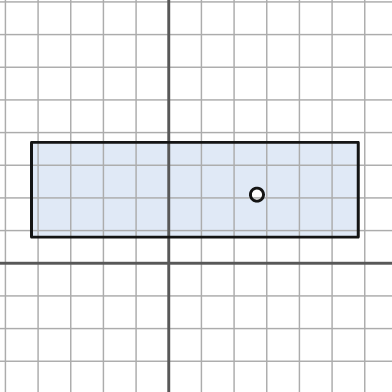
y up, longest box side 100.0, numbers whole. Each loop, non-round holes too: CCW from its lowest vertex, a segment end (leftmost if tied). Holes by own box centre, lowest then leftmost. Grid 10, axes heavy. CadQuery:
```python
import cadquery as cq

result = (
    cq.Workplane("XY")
    .moveTo(-42.0, 8.0)
    .lineTo(58.0, 8.0)
    .lineTo(58.0, 37.0)
    .lineTo(-42.0, 37.0)
    .close()
    .moveTo(27.0, 21.0)
    .circle(2.0)
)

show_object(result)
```